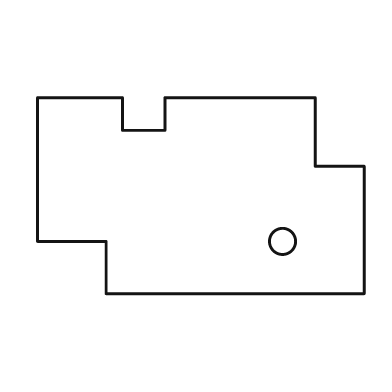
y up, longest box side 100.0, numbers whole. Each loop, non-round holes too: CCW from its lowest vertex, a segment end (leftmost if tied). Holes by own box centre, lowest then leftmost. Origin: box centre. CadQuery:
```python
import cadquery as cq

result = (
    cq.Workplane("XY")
    .moveTo(-29.0, -30.0)
    .lineTo(50.0, -30.0)
    .lineTo(50.0, 9.0)
    .lineTo(35.0, 9.0)
    .lineTo(35.0, 30.0)
    .lineTo(-11.0, 30.0)
    .lineTo(-11.0, 20.0)
    .lineTo(-24.0, 20.0)
    .lineTo(-24.0, 30.0)
    .lineTo(-50.0, 30.0)
    .lineTo(-50.0, -14.0)
    .lineTo(-29.0, -14.0)
    .close()
    .moveTo(25.0, -14.0)
    .circle(4.0)
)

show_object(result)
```